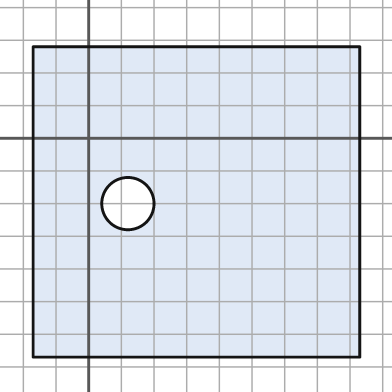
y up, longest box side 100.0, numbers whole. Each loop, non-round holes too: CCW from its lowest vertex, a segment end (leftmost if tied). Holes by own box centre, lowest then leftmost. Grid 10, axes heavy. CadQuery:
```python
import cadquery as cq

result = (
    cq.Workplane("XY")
    .moveTo(-17.0, -67.0)
    .lineTo(83.0, -67.0)
    .lineTo(83.0, 28.0)
    .lineTo(-17.0, 28.0)
    .close()
    .moveTo(12.0, -20.0)
    .circle(8.0)
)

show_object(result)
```